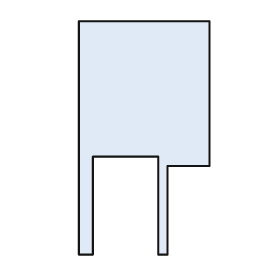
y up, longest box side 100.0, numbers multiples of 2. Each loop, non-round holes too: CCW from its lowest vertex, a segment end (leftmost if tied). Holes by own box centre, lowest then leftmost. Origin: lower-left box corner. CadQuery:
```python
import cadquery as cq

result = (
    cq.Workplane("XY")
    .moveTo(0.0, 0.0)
    .lineTo(6.0, 0.0)
    .lineTo(6.0, 42.0)
    .lineTo(34.0, 42.0)
    .lineTo(34.0, 0.0)
    .lineTo(38.0, 0.0)
    .lineTo(38.0, 38.0)
    .lineTo(56.0, 38.0)
    .lineTo(56.0, 100.0)
    .lineTo(0.0, 100.0)
    .close()
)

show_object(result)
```